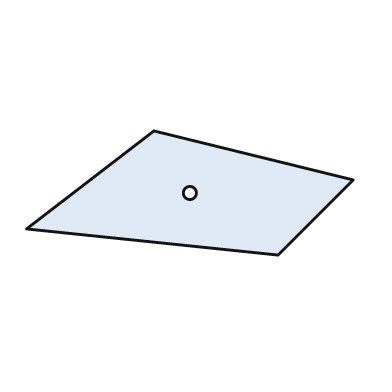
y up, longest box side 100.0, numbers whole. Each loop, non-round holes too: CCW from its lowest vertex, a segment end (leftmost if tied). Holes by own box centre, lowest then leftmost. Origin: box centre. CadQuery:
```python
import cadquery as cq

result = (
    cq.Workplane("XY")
    .moveTo(27.0, -19.0)
    .lineTo(50.0, 4.0)
    .lineTo(-11.0, 19.0)
    .lineTo(-50.0, -11.0)
    .close()
    .moveTo(0.0, 0.0)
    .circle(2.0)
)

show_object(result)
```